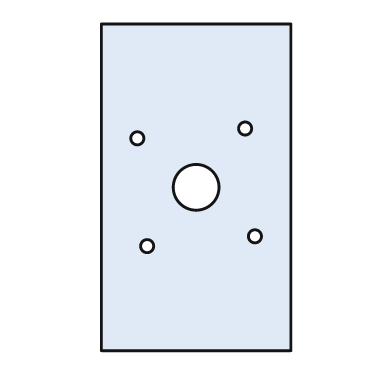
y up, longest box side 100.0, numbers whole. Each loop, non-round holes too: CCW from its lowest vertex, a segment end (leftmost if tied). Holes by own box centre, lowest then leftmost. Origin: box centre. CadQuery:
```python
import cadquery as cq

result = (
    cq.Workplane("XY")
    .moveTo(-29.0, -50.0)
    .lineTo(29.0, -50.0)
    .lineTo(29.0, 50.0)
    .lineTo(-29.0, 50.0)
    .close()
    .moveTo(-15.0, -18.0)
    .circle(2.0)
    .moveTo(18.0, -15.0)
    .circle(2.0)
    .moveTo(0.0, 0.0)
    .circle(7.0)
    .moveTo(-18.0, 15.0)
    .circle(2.0)
    .moveTo(15.0, 18.0)
    .circle(2.0)
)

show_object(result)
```